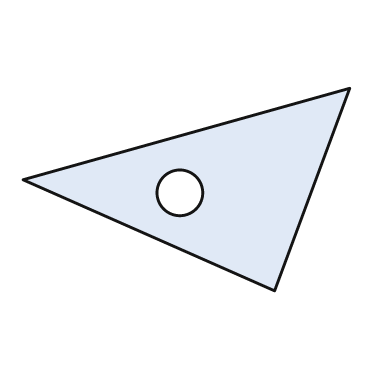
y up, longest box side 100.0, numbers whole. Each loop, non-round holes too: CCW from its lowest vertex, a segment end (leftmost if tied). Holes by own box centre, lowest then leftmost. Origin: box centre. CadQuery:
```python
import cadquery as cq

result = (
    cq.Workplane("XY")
    .moveTo(27.0, -31.0)
    .lineTo(50.0, 31.0)
    .lineTo(-50.0, 3.0)
    .close()
    .moveTo(-2.0, -1.0)
    .circle(7.0)
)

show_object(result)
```